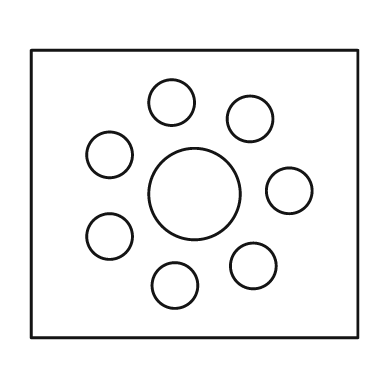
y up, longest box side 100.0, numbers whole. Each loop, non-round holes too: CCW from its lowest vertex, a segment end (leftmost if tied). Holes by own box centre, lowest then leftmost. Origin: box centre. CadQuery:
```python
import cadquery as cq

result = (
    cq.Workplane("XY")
    .moveTo(-50.0, -44.0)
    .lineTo(50.0, -44.0)
    .lineTo(50.0, 44.0)
    .lineTo(-50.0, 44.0)
    .close()
    .moveTo(-6.0, -28.0)
    .circle(7.0)
    .moveTo(18.0, -22.0)
    .circle(7.0)
    .moveTo(-26.0, -13.0)
    .circle(7.0)
    .moveTo(0.0, 0.0)
    .circle(14.0)
    .moveTo(29.0, 1.0)
    .circle(7.0)
    .moveTo(-26.0, 12.0)
    .circle(7.0)
    .moveTo(17.0, 23.0)
    .circle(7.0)
    .moveTo(-7.0, 28.0)
    .circle(7.0)
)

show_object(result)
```